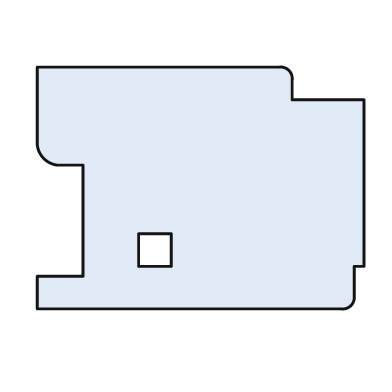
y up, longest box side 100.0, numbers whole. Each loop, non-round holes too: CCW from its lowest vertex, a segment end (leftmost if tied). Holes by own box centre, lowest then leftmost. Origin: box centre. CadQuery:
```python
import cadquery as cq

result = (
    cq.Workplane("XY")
    .moveTo(-50.0, -37.0)
    .lineTo(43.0, -37.0)
    .threePointArc((46.0, -36.0), (47.0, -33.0))
    .lineTo(47.0, -24.0)
    .lineTo(50.0, -24.0)
    .lineTo(50.0, 27.0)
    .lineTo(28.0, 27.0)
    .lineTo(28.0, 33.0)
    .threePointArc((27.0, 36.0), (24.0, 37.0))
    .lineTo(-50.0, 37.0)
    .lineTo(-50.0, 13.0)
    .threePointArc((-48.0, 9.0), (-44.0, 7.0))
    .lineTo(-36.0, 7.0)
    .lineTo(-36.0, -27.0)
    .lineTo(-50.0, -27.0)
    .close()
    .moveTo(-19.0, -24.0)
    .lineTo(-9.0, -24.0)
    .lineTo(-9.0, -14.0)
    .lineTo(-19.0, -14.0)
    .close()
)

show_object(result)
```